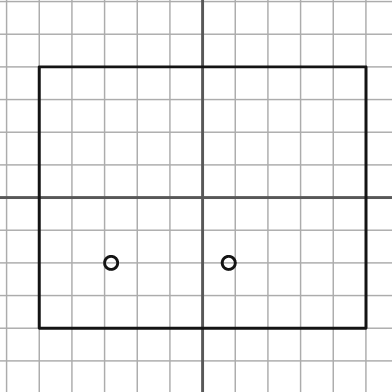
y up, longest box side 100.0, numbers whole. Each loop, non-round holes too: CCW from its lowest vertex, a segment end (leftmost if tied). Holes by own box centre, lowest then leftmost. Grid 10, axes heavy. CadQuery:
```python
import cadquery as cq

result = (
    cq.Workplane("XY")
    .moveTo(-50.0, -40.0)
    .lineTo(50.0, -40.0)
    .lineTo(50.0, 40.0)
    .lineTo(-50.0, 40.0)
    .close()
    .moveTo(-28.0, -20.0)
    .circle(2.0)
    .moveTo(8.0, -20.0)
    .circle(2.0)
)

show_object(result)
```